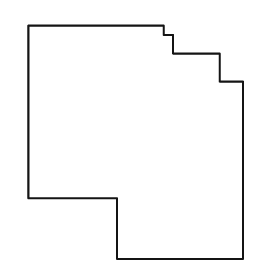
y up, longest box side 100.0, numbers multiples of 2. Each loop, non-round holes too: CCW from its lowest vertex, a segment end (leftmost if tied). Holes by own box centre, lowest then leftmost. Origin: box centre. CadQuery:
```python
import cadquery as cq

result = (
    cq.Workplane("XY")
    .moveTo(-8.0, -50.0)
    .lineTo(46.0, -50.0)
    .lineTo(46.0, 26.0)
    .lineTo(36.0, 26.0)
    .lineTo(36.0, 38.0)
    .lineTo(16.0, 38.0)
    .lineTo(16.0, 46.0)
    .lineTo(12.0, 46.0)
    .lineTo(12.0, 50.0)
    .lineTo(-46.0, 50.0)
    .lineTo(-46.0, -24.0)
    .lineTo(-8.0, -24.0)
    .close()
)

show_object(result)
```